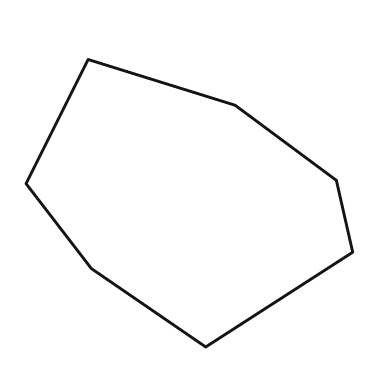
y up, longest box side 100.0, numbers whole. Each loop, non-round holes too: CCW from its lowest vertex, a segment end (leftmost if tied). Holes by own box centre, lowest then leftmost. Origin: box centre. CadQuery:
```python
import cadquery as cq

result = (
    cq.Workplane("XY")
    .moveTo(5.0, -44.0)
    .lineTo(50.0, -15.0)
    .lineTo(45.0, 7.0)
    .lineTo(14.0, 30.0)
    .lineTo(-31.0, 44.0)
    .lineTo(-50.0, 6.0)
    .lineTo(-30.0, -20.0)
    .close()
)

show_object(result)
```